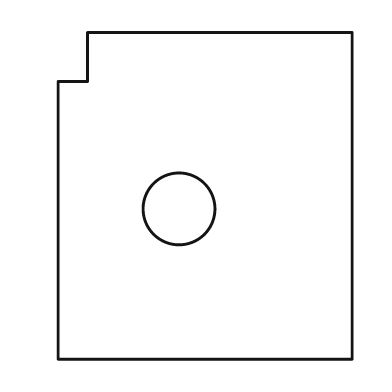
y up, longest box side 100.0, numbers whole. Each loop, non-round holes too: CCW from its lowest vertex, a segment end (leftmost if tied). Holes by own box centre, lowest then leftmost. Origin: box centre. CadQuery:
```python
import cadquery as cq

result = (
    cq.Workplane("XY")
    .moveTo(-45.0, -50.0)
    .lineTo(45.0, -50.0)
    .lineTo(45.0, 50.0)
    .lineTo(-36.0, 50.0)
    .lineTo(-36.0, 35.0)
    .lineTo(-45.0, 35.0)
    .close()
    .moveTo(-8.0, -4.0)
    .circle(11.0)
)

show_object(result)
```